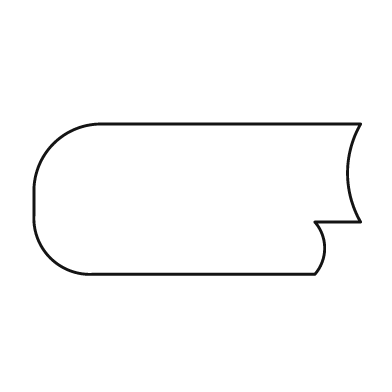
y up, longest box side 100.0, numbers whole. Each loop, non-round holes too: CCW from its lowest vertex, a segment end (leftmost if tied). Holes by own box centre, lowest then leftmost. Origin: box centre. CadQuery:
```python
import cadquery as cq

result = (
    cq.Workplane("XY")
    .moveTo(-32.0, -23.0)
    .lineTo(36.0, -23.0)
    .threePointArc((39.0, -15.0), (36.0, -7.0))
    .lineTo(50.0, -7.0)
    .threePointArc((46.0, 8.0), (50.0, 23.0))
    .lineTo(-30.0, 23.0)
    .threePointArc((-44.0, 17.0), (-50.0, 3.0))
    .lineTo(-50.0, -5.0)
    .threePointArc((-45.0, -18.0), (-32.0, -23.0))
    .close()
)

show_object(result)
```